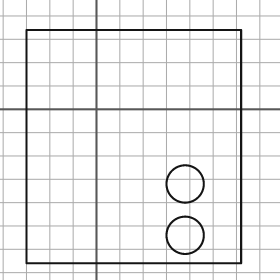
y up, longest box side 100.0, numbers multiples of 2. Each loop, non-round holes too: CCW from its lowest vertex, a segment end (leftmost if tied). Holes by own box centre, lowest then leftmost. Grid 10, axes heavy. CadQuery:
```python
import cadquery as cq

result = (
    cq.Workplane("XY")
    .moveTo(-30.0, -66.0)
    .lineTo(62.0, -66.0)
    .lineTo(62.0, 34.0)
    .lineTo(-30.0, 34.0)
    .close()
    .moveTo(38.0, -54.0)
    .circle(8.0)
    .moveTo(38.0, -32.0)
    .circle(8.0)
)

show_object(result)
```